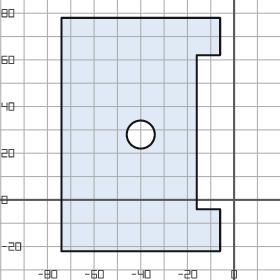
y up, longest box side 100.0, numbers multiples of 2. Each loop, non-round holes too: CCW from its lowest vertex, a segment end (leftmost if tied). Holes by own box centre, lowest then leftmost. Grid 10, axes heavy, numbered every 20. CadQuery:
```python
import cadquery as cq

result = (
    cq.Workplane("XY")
    .moveTo(-74.0, -22.0)
    .lineTo(-6.0, -22.0)
    .lineTo(-6.0, -4.0)
    .lineTo(-16.0, -4.0)
    .lineTo(-16.0, 62.0)
    .lineTo(-6.0, 62.0)
    .lineTo(-6.0, 78.0)
    .lineTo(-74.0, 78.0)
    .close()
    .moveTo(-40.0, 28.0)
    .circle(6.0)
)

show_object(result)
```